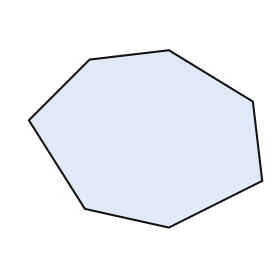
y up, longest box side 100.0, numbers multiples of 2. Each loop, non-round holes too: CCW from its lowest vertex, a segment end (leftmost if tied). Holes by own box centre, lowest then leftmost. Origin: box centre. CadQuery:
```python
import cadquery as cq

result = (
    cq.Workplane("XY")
    .moveTo(10.0, -38.0)
    .lineTo(50.0, -18.0)
    .lineTo(46.0, 16.0)
    .lineTo(10.0, 38.0)
    .lineTo(-24.0, 34.0)
    .lineTo(-50.0, 8.0)
    .lineTo(-26.0, -30.0)
    .close()
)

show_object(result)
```